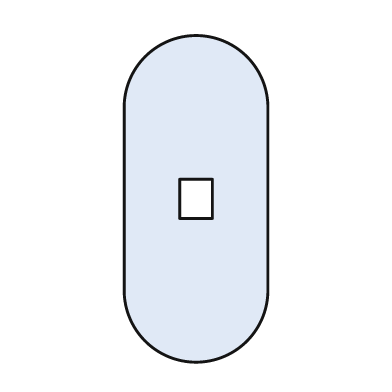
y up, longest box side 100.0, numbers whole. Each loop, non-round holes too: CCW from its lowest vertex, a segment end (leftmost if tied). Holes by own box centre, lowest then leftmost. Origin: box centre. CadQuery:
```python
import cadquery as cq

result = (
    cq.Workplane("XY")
    .moveTo(-22.0, -28.0)
    .threePointArc((0.0, -50.0), (22.0, -28.0))
    .lineTo(22.0, 28.0)
    .threePointArc((0.0, 50.0), (-22.0, 28.0))
    .close()
    .moveTo(-5.0, -6.0)
    .lineTo(5.0, -6.0)
    .lineTo(5.0, 6.0)
    .lineTo(-5.0, 6.0)
    .close()
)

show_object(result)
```